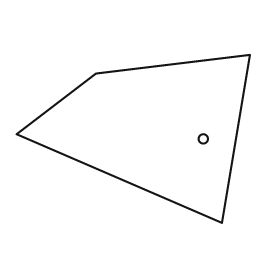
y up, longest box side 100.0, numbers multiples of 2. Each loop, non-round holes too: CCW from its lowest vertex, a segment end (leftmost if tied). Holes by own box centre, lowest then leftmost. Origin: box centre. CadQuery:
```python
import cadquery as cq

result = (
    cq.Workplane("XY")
    .moveTo(38.0, -36.0)
    .lineTo(50.0, 36.0)
    .lineTo(-16.0, 28.0)
    .lineTo(-50.0, 2.0)
    .close()
    .moveTo(30.0, 0.0)
    .circle(2.0)
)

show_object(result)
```